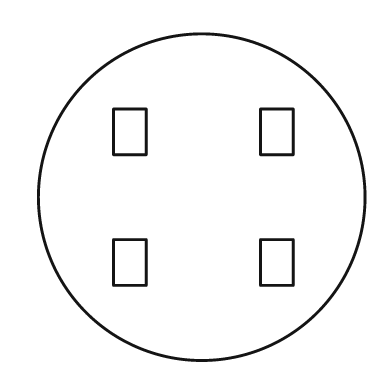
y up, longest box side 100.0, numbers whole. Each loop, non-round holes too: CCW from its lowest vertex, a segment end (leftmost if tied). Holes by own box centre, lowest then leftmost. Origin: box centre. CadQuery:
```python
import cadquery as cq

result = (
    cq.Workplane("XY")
    .moveTo(0.0, 0.0)
    .circle(50.0)
    .moveTo(-27.0, -27.0)
    .lineTo(-17.0, -27.0)
    .lineTo(-17.0, -13.0)
    .lineTo(-27.0, -13.0)
    .close()
    .moveTo(18.0, -27.0)
    .lineTo(28.0, -27.0)
    .lineTo(28.0, -13.0)
    .lineTo(18.0, -13.0)
    .close()
    .moveTo(-27.0, 13.0)
    .lineTo(-17.0, 13.0)
    .lineTo(-17.0, 27.0)
    .lineTo(-27.0, 27.0)
    .close()
    .moveTo(18.0, 13.0)
    .lineTo(28.0, 13.0)
    .lineTo(28.0, 27.0)
    .lineTo(18.0, 27.0)
    .close()
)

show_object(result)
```